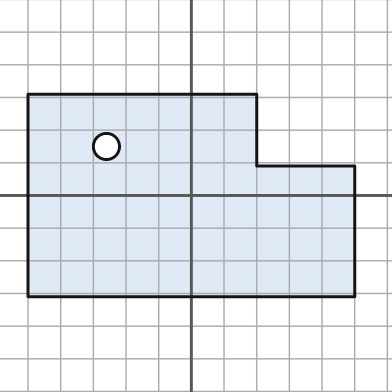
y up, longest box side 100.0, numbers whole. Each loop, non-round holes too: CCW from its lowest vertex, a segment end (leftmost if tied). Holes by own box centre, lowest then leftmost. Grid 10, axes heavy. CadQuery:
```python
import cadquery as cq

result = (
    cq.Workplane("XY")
    .moveTo(-50.0, -31.0)
    .lineTo(50.0, -31.0)
    .lineTo(50.0, 9.0)
    .lineTo(20.0, 9.0)
    .lineTo(20.0, 31.0)
    .lineTo(-50.0, 31.0)
    .close()
    .moveTo(-26.0, 15.0)
    .circle(4.0)
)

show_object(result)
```